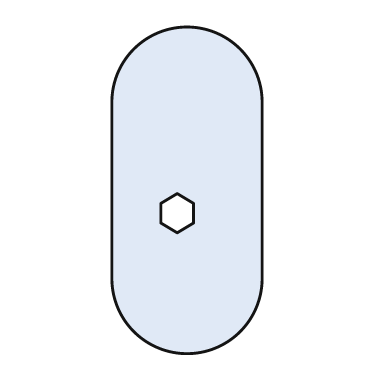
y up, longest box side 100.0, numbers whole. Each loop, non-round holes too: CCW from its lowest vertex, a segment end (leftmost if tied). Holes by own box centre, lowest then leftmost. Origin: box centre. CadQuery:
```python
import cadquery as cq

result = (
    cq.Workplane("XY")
    .moveTo(-23.0, -27.0)
    .threePointArc((0.0, -50.0), (23.0, -27.0))
    .lineTo(23.0, 27.0)
    .threePointArc((0.0, 50.0), (-23.0, 27.0))
    .close()
    .moveTo(-3.0, -13.0)
    .lineTo(2.0, -10.0)
    .lineTo(2.0, -4.0)
    .lineTo(-3.0, -1.0)
    .lineTo(-8.0, -4.0)
    .lineTo(-8.0, -10.0)
    .close()
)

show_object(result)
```